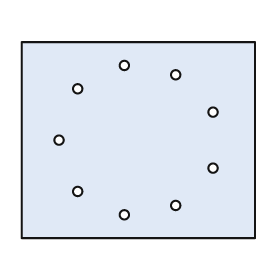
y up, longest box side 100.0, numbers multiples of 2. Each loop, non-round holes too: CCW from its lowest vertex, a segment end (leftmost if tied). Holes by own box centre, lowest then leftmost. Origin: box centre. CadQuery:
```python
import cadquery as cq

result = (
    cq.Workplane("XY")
    .moveTo(-50.0, -42.0)
    .lineTo(50.0, -42.0)
    .lineTo(50.0, 42.0)
    .lineTo(-50.0, 42.0)
    .close()
    .moveTo(-6.0, -32.0)
    .circle(2.0)
    .moveTo(16.0, -28.0)
    .circle(2.0)
    .moveTo(-26.0, -22.0)
    .circle(2.0)
    .moveTo(32.0, -12.0)
    .circle(2.0)
    .moveTo(-34.0, 0.0)
    .circle(2.0)
    .moveTo(32.0, 12.0)
    .circle(2.0)
    .moveTo(-26.0, 22.0)
    .circle(2.0)
    .moveTo(16.0, 28.0)
    .circle(2.0)
    .moveTo(-6.0, 32.0)
    .circle(2.0)
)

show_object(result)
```